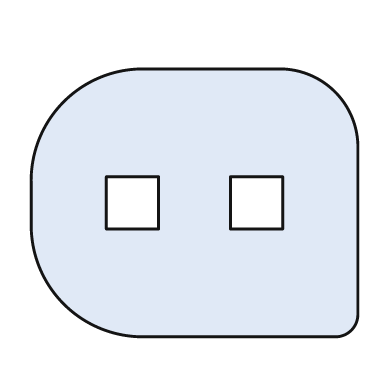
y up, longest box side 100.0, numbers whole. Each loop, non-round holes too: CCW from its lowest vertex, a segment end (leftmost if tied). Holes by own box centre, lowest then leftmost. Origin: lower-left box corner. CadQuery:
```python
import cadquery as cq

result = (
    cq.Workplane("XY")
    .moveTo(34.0, 0.0)
    .lineTo(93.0, 0.0)
    .threePointArc((98.0, 2.0), (100.0, 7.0))
    .lineTo(100.0, 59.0)
    .threePointArc((93.0, 75.0), (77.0, 82.0))
    .lineTo(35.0, 82.0)
    .threePointArc((10.0, 72.0), (0.0, 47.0))
    .lineTo(0.0, 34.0)
    .threePointArc((10.0, 10.0), (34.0, 0.0))
    .close()
    .moveTo(23.0, 33.0)
    .lineTo(39.0, 33.0)
    .lineTo(39.0, 49.0)
    .lineTo(23.0, 49.0)
    .close()
    .moveTo(61.0, 33.0)
    .lineTo(77.0, 33.0)
    .lineTo(77.0, 49.0)
    .lineTo(61.0, 49.0)
    .close()
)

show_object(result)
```